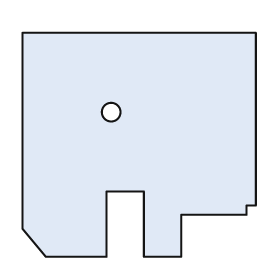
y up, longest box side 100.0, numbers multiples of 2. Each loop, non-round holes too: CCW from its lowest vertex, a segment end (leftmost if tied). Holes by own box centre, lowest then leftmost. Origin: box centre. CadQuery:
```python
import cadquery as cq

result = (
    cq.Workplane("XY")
    .moveTo(-40.0, -48.0)
    .lineTo(-14.0, -48.0)
    .lineTo(-14.0, -20.0)
    .lineTo(2.0, -20.0)
    .lineTo(2.0, -48.0)
    .lineTo(18.0, -48.0)
    .lineTo(18.0, -30.0)
    .lineTo(46.0, -30.0)
    .lineTo(46.0, -26.0)
    .lineTo(50.0, -26.0)
    .lineTo(50.0, 48.0)
    .lineTo(-50.0, 48.0)
    .lineTo(-50.0, -36.0)
    .close()
    .moveTo(-12.0, 14.0)
    .circle(4.0)
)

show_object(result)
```